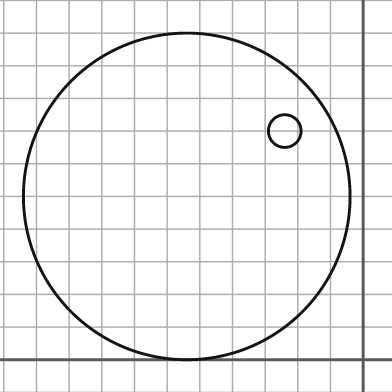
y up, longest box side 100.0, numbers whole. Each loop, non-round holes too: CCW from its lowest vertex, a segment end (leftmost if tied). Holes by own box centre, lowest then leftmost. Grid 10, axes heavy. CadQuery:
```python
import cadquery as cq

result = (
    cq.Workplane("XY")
    .moveTo(-54.0, 50.0)
    .circle(50.0)
    .moveTo(-24.0, 70.0)
    .circle(5.0)
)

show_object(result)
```